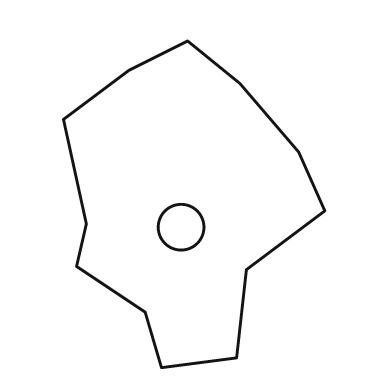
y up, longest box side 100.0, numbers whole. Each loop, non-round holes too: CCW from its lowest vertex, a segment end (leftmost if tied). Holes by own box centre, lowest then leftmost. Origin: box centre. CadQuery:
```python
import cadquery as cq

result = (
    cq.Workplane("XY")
    .moveTo(-10.0, -50.0)
    .lineTo(13.0, -47.0)
    .lineTo(16.0, -20.0)
    .lineTo(40.0, -2.0)
    .lineTo(32.0, 16.0)
    .lineTo(14.0, 37.0)
    .lineTo(-2.0, 50.0)
    .lineTo(-20.0, 41.0)
    .lineTo(-40.0, 26.0)
    .lineTo(-33.0, -6.0)
    .lineTo(-36.0, -19.0)
    .lineTo(-15.0, -33.0)
    .close()
    .moveTo(-4.0, -7.0)
    .circle(7.0)
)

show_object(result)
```